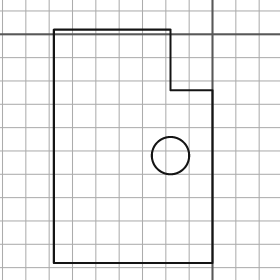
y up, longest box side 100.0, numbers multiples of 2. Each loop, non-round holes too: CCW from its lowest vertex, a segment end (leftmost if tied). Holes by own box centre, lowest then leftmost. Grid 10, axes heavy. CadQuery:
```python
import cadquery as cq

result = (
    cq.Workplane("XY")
    .moveTo(-68.0, -98.0)
    .lineTo(0.0, -98.0)
    .lineTo(0.0, -24.0)
    .lineTo(-18.0, -24.0)
    .lineTo(-18.0, 2.0)
    .lineTo(-68.0, 2.0)
    .close()
    .moveTo(-18.0, -52.0)
    .circle(8.0)
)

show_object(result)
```